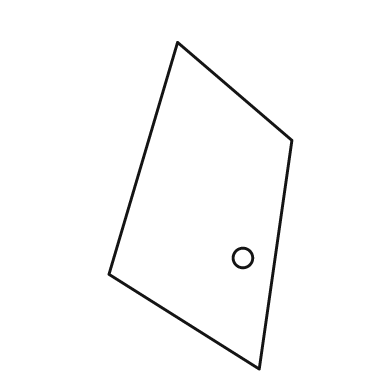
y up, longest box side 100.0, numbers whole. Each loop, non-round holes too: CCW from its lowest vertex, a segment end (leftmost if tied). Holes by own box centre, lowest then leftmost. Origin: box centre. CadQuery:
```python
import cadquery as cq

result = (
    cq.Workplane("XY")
    .moveTo(18.0, -50.0)
    .lineTo(28.0, 20.0)
    .lineTo(-7.0, 50.0)
    .lineTo(-28.0, -21.0)
    .close()
    .moveTo(13.0, -16.0)
    .circle(3.0)
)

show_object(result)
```